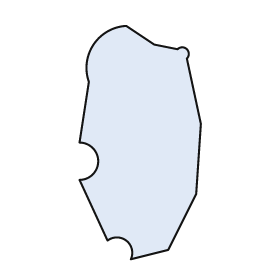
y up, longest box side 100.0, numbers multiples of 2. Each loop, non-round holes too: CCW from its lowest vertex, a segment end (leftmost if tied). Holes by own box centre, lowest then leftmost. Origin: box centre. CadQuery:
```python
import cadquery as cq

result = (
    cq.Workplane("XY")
    .moveTo(-4.0, -50.0)
    .lineTo(12.0, -46.0)
    .lineTo(24.0, -22.0)
    .lineTo(26.0, 8.0)
    .lineTo(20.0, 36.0)
    .threePointArc((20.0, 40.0), (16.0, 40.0))
    .lineTo(6.0, 42.0)
    .lineTo(-6.0, 50.0)
    .threePointArc((-20.0, 42.0), (-22.0, 26.0))
    .lineTo(-26.0, 0.0)
    .threePointArc((-18.0, -8.0), (-26.0, -16.0))
    .lineTo(-14.0, -42.0)
    .threePointArc((-6.0, -42.0), (-4.0, -50.0))
    .close()
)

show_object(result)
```